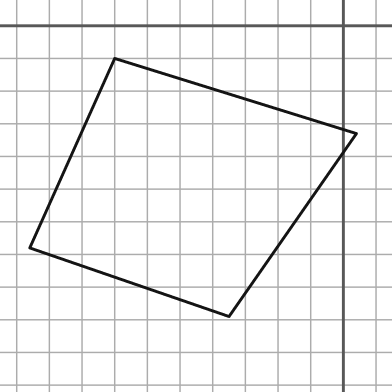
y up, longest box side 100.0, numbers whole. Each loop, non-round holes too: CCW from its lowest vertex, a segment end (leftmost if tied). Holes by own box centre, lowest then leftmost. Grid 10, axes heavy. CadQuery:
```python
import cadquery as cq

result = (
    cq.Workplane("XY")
    .moveTo(-35.0, -89.0)
    .lineTo(4.0, -33.0)
    .lineTo(-70.0, -10.0)
    .lineTo(-96.0, -68.0)
    .close()
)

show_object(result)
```